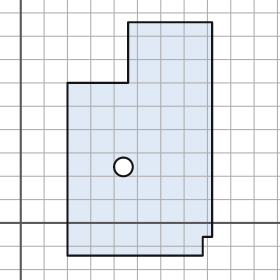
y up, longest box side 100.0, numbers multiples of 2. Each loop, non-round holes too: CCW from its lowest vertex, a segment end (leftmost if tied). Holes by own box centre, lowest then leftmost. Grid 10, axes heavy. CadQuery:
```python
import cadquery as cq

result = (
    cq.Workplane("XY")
    .moveTo(20.0, -14.0)
    .lineTo(78.0, -14.0)
    .lineTo(78.0, -6.0)
    .lineTo(82.0, -6.0)
    .lineTo(82.0, 86.0)
    .lineTo(46.0, 86.0)
    .lineTo(46.0, 60.0)
    .lineTo(20.0, 60.0)
    .close()
    .moveTo(44.0, 24.0)
    .circle(4.0)
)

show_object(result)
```